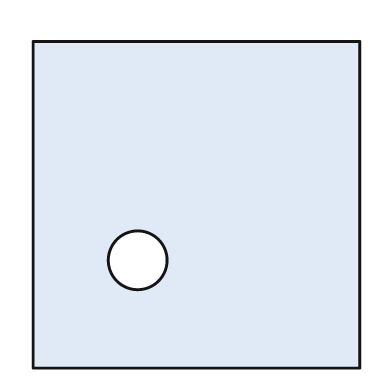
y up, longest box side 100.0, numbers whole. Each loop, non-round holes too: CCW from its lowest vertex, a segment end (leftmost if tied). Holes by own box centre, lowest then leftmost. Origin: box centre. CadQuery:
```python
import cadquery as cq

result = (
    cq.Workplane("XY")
    .moveTo(-50.0, -50.0)
    .lineTo(50.0, -50.0)
    .lineTo(50.0, 50.0)
    .lineTo(-50.0, 50.0)
    .close()
    .moveTo(-18.0, -17.0)
    .circle(9.0)
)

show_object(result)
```